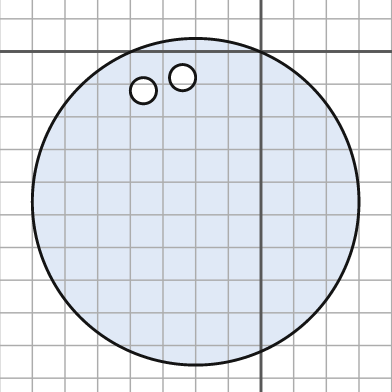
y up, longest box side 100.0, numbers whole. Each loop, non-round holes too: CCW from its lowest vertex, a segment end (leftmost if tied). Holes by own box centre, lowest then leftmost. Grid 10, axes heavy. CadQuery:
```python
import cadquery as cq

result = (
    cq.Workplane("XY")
    .moveTo(-20.0, -46.0)
    .circle(50.0)
    .moveTo(-36.0, -12.0)
    .circle(4.0)
    .moveTo(-24.0, -8.0)
    .circle(4.0)
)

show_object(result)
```